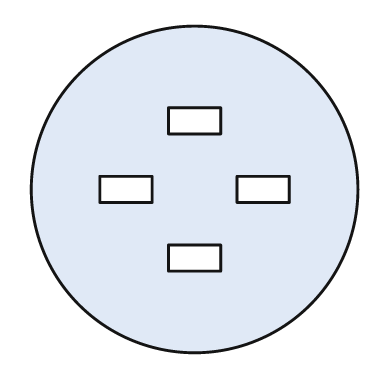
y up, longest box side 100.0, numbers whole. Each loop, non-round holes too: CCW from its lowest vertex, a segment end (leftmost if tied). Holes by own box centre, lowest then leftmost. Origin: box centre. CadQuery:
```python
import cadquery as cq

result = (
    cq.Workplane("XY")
    .moveTo(0.0, 0.0)
    .circle(50.0)
    .moveTo(-8.0, -25.0)
    .lineTo(8.0, -25.0)
    .lineTo(8.0, -17.0)
    .lineTo(-8.0, -17.0)
    .close()
    .moveTo(-29.0, -4.0)
    .lineTo(-13.0, -4.0)
    .lineTo(-13.0, 4.0)
    .lineTo(-29.0, 4.0)
    .close()
    .moveTo(13.0, -4.0)
    .lineTo(29.0, -4.0)
    .lineTo(29.0, 4.0)
    .lineTo(13.0, 4.0)
    .close()
    .moveTo(-8.0, 17.0)
    .lineTo(8.0, 17.0)
    .lineTo(8.0, 25.0)
    .lineTo(-8.0, 25.0)
    .close()
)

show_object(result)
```